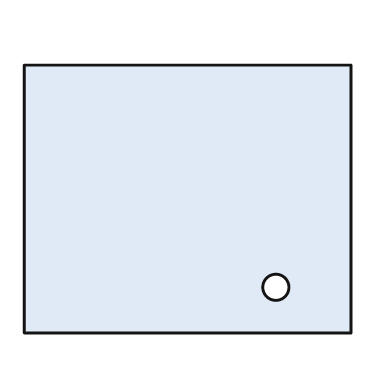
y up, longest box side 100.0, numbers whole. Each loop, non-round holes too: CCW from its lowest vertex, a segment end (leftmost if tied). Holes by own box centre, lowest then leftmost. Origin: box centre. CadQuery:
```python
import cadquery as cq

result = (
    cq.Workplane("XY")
    .moveTo(-50.0, -41.0)
    .lineTo(50.0, -41.0)
    .lineTo(50.0, 41.0)
    .lineTo(-50.0, 41.0)
    .close()
    .moveTo(27.0, -27.0)
    .circle(4.0)
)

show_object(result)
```